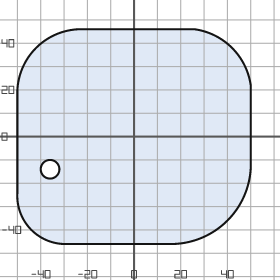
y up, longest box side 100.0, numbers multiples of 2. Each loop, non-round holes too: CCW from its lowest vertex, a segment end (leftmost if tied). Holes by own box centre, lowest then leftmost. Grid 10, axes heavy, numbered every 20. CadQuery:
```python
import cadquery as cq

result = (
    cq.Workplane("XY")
    .moveTo(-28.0, -46.0)
    .lineTo(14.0, -46.0)
    .threePointArc((40.0, -36.0), (50.0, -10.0))
    .lineTo(50.0, 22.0)
    .threePointArc((42.0, 38.0), (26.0, 46.0))
    .lineTo(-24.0, 46.0)
    .threePointArc((-42.0, 38.0), (-50.0, 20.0))
    .lineTo(-50.0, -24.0)
    .threePointArc((-44.0, -40.0), (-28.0, -46.0))
    .close()
    .moveTo(-36.0, -14.0)
    .circle(4.0)
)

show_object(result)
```